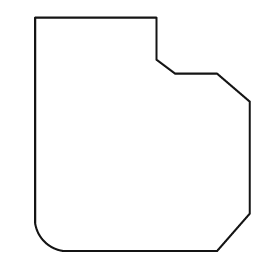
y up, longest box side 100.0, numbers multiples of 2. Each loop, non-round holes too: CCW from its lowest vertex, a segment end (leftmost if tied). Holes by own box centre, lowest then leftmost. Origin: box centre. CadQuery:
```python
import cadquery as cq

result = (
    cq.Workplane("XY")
    .moveTo(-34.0, -50.0)
    .lineTo(32.0, -50.0)
    .lineTo(46.0, -34.0)
    .lineTo(46.0, 14.0)
    .lineTo(32.0, 26.0)
    .lineTo(14.0, 26.0)
    .lineTo(6.0, 32.0)
    .lineTo(6.0, 50.0)
    .lineTo(-46.0, 50.0)
    .lineTo(-46.0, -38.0)
    .threePointArc((-42.0, -46.0), (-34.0, -50.0))
    .close()
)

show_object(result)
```